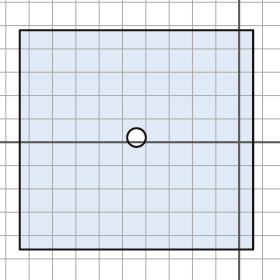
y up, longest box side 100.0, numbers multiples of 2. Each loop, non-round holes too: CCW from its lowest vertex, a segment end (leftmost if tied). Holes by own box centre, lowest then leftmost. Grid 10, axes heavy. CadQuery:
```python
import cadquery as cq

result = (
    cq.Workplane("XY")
    .moveTo(-94.0, -46.0)
    .lineTo(6.0, -46.0)
    .lineTo(6.0, 48.0)
    .lineTo(-94.0, 48.0)
    .close()
    .moveTo(-44.0, 2.0)
    .circle(4.0)
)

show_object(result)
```